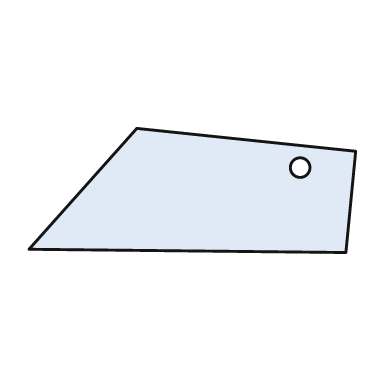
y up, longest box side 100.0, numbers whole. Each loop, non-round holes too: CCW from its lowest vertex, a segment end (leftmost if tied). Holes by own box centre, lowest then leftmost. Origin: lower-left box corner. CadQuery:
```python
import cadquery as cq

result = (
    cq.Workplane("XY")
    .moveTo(97.0, 0.0)
    .lineTo(100.0, 31.0)
    .lineTo(33.0, 38.0)
    .lineTo(0.0, 1.0)
    .close()
    .moveTo(83.0, 26.0)
    .circle(3.0)
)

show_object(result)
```